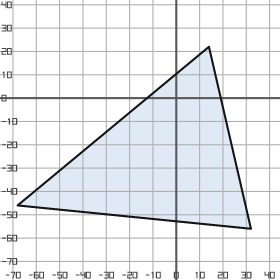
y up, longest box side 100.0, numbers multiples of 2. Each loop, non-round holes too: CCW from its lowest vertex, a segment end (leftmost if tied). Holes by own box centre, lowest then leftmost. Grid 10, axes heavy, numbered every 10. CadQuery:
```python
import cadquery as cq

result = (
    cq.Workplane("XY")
    .moveTo(32.0, -56.0)
    .lineTo(14.0, 22.0)
    .lineTo(-68.0, -46.0)
    .close()
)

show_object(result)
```